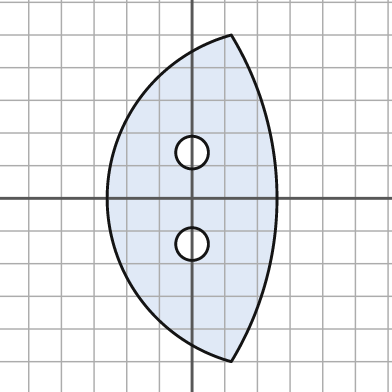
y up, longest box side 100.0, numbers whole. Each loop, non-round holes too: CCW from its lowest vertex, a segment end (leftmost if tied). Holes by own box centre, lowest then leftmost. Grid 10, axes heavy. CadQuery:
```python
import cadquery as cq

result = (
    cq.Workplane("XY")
    .moveTo(12.0, -50.0)
    .threePointArc((26.0, 0.0), (12.0, 50.0))
    .threePointArc((-26.0, 0.0), (12.0, -50.0))
    .close()
    .moveTo(0.0, -14.0)
    .circle(5.0)
    .moveTo(0.0, 14.0)
    .circle(5.0)
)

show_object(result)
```